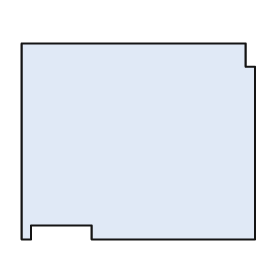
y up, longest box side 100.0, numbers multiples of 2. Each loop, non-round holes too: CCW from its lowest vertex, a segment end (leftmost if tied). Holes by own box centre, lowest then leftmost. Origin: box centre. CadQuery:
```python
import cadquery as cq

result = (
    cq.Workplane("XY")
    .moveTo(-50.0, -42.0)
    .lineTo(-46.0, -42.0)
    .lineTo(-46.0, -36.0)
    .lineTo(-20.0, -36.0)
    .lineTo(-20.0, -42.0)
    .lineTo(50.0, -42.0)
    .lineTo(50.0, 32.0)
    .lineTo(46.0, 32.0)
    .lineTo(46.0, 42.0)
    .lineTo(-50.0, 42.0)
    .close()
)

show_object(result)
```